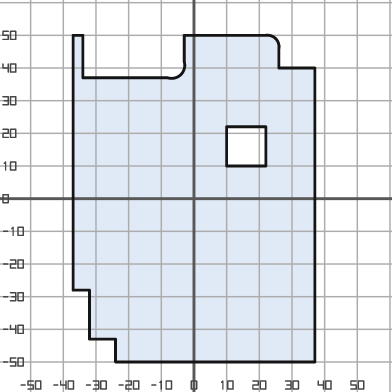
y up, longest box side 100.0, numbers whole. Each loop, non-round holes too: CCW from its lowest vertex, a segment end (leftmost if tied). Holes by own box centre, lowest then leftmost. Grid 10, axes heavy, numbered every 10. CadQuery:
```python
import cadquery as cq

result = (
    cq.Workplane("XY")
    .moveTo(-24.0, -50.0)
    .lineTo(37.0, -50.0)
    .lineTo(37.0, 40.0)
    .lineTo(26.0, 40.0)
    .lineTo(26.0, 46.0)
    .threePointArc((25.0, 49.0), (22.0, 50.0))
    .lineTo(-3.0, 50.0)
    .lineTo(-3.0, 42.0)
    .threePointArc((-4.0, 38.0), (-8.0, 37.0))
    .lineTo(-34.0, 37.0)
    .lineTo(-34.0, 50.0)
    .lineTo(-37.0, 50.0)
    .lineTo(-37.0, -28.0)
    .lineTo(-32.0, -28.0)
    .lineTo(-32.0, -43.0)
    .lineTo(-24.0, -43.0)
    .close()
    .moveTo(10.0, 10.0)
    .lineTo(22.0, 10.0)
    .lineTo(22.0, 22.0)
    .lineTo(10.0, 22.0)
    .close()
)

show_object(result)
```